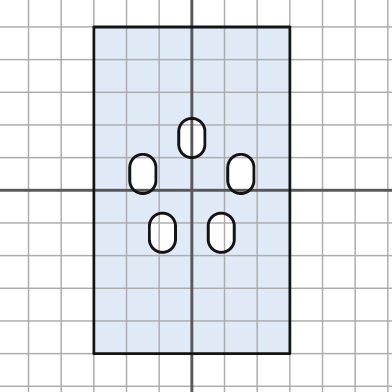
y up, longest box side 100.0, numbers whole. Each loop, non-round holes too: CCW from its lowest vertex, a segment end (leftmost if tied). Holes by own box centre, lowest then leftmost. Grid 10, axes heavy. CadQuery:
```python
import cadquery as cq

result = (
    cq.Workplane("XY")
    .moveTo(-30.0, -50.0)
    .lineTo(30.0, -50.0)
    .lineTo(30.0, 50.0)
    .lineTo(-30.0, 50.0)
    .close()
    .moveTo(-13.0, -15.0)
    .threePointArc((-9.0, -19.0), (-5.0, -15.0))
    .lineTo(-5.0, -11.0)
    .threePointArc((-9.0, -7.0), (-13.0, -11.0))
    .close()
    .moveTo(5.0, -15.0)
    .threePointArc((9.0, -19.0), (13.0, -15.0))
    .lineTo(13.0, -11.0)
    .threePointArc((9.0, -7.0), (5.0, -11.0))
    .close()
    .moveTo(-19.0, 3.0)
    .threePointArc((-15.0, -1.0), (-11.0, 3.0))
    .lineTo(-11.0, 7.0)
    .threePointArc((-15.0, 11.0), (-19.0, 7.0))
    .close()
    .moveTo(11.0, 3.0)
    .threePointArc((15.0, -1.0), (19.0, 3.0))
    .lineTo(19.0, 7.0)
    .threePointArc((15.0, 11.0), (11.0, 7.0))
    .close()
    .moveTo(-4.0, 14.0)
    .threePointArc((0.0, 10.0), (4.0, 14.0))
    .lineTo(4.0, 18.0)
    .threePointArc((0.0, 22.0), (-4.0, 18.0))
    .close()
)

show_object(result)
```